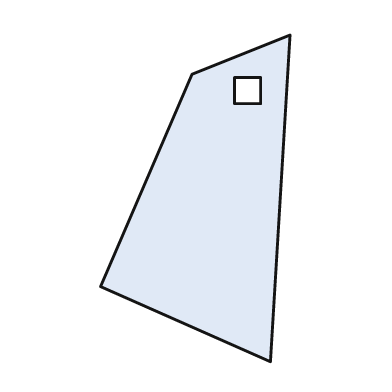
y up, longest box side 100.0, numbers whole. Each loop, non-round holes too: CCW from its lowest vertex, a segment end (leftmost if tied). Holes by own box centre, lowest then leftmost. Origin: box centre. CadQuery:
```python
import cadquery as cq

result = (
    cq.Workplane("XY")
    .moveTo(23.0, -50.0)
    .lineTo(29.0, 50.0)
    .lineTo(-1.0, 38.0)
    .lineTo(-29.0, -27.0)
    .close()
    .moveTo(12.0, 29.0)
    .lineTo(20.0, 29.0)
    .lineTo(20.0, 37.0)
    .lineTo(12.0, 37.0)
    .close()
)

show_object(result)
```